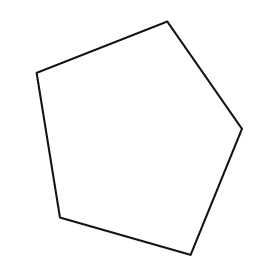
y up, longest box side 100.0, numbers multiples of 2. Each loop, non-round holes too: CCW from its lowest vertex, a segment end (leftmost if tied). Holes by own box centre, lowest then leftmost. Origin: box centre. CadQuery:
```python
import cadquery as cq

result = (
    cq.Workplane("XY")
    .moveTo(22.0, -50.0)
    .lineTo(44.0, 4.0)
    .lineTo(12.0, 50.0)
    .lineTo(-44.0, 28.0)
    .lineTo(-34.0, -34.0)
    .close()
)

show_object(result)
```